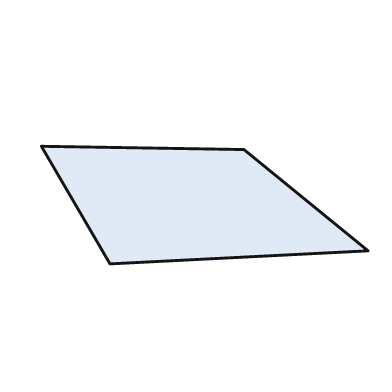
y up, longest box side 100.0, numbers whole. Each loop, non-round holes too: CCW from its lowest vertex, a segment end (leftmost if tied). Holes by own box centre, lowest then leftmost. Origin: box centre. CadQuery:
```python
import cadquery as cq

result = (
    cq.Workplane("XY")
    .moveTo(-29.0, -18.0)
    .lineTo(50.0, -14.0)
    .lineTo(12.0, 17.0)
    .lineTo(-50.0, 18.0)
    .close()
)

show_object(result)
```